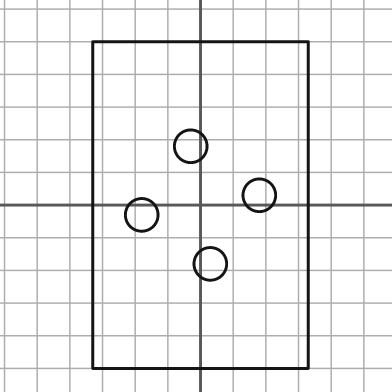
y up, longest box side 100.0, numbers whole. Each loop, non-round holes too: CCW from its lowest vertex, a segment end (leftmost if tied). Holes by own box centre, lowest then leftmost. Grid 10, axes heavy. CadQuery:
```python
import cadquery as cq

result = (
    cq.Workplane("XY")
    .moveTo(-33.0, -50.0)
    .lineTo(33.0, -50.0)
    .lineTo(33.0, 50.0)
    .lineTo(-33.0, 50.0)
    .close()
    .moveTo(3.0, -18.0)
    .circle(5.0)
    .moveTo(-18.0, -3.0)
    .circle(5.0)
    .moveTo(18.0, 3.0)
    .circle(5.0)
    .moveTo(-3.0, 18.0)
    .circle(5.0)
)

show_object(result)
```